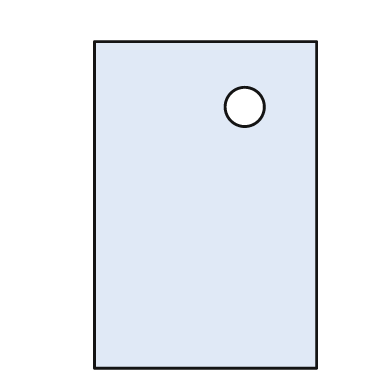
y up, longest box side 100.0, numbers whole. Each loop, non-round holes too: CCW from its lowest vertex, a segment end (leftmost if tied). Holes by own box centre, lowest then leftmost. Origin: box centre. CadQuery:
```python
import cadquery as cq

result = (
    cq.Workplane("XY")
    .moveTo(-34.0, -50.0)
    .lineTo(34.0, -50.0)
    .lineTo(34.0, 50.0)
    .lineTo(-34.0, 50.0)
    .close()
    .moveTo(12.0, 30.0)
    .circle(6.0)
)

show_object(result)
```